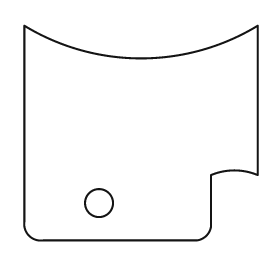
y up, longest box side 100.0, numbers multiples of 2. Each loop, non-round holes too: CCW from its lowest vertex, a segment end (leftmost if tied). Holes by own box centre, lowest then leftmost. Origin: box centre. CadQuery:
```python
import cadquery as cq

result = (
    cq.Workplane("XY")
    .moveTo(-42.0, -46.0)
    .lineTo(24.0, -46.0)
    .threePointArc((28.0, -44.0), (30.0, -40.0))
    .lineTo(30.0, -18.0)
    .threePointArc((40.0, -16.0), (50.0, -18.0))
    .lineTo(50.0, 46.0)
    .threePointArc((0.0, 32.0), (-50.0, 46.0))
    .lineTo(-50.0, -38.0)
    .threePointArc((-48.0, -44.0), (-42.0, -46.0))
    .close()
    .moveTo(-18.0, -30.0)
    .circle(6.0)
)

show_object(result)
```